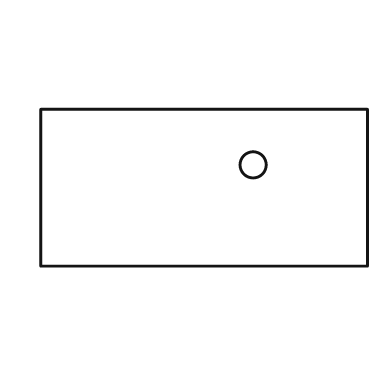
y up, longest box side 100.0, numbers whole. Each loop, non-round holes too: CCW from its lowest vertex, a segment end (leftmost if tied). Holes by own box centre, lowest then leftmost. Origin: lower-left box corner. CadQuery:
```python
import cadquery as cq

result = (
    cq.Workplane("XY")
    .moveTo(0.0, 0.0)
    .lineTo(100.0, 0.0)
    .lineTo(100.0, 48.0)
    .lineTo(0.0, 48.0)
    .close()
    .moveTo(65.0, 31.0)
    .circle(4.0)
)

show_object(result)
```